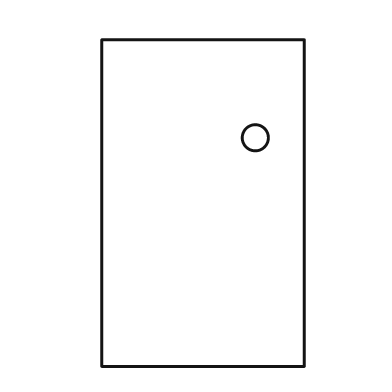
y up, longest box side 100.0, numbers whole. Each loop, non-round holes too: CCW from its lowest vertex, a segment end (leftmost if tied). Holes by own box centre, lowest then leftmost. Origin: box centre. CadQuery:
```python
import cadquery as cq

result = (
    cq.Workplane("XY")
    .moveTo(-31.0, -50.0)
    .lineTo(31.0, -50.0)
    .lineTo(31.0, 50.0)
    .lineTo(-31.0, 50.0)
    .close()
    .moveTo(16.0, 20.0)
    .circle(4.0)
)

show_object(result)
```